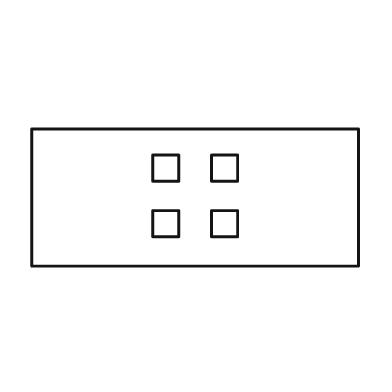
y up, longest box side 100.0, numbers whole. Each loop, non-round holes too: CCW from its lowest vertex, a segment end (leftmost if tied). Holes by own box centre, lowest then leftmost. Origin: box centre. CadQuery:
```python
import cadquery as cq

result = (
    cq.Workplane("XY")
    .moveTo(-50.0, -21.0)
    .lineTo(50.0, -21.0)
    .lineTo(50.0, 21.0)
    .lineTo(-50.0, 21.0)
    .close()
    .moveTo(-13.0, -12.0)
    .lineTo(-5.0, -12.0)
    .lineTo(-5.0, -4.0)
    .lineTo(-13.0, -4.0)
    .close()
    .moveTo(5.0, -12.0)
    .lineTo(13.0, -12.0)
    .lineTo(13.0, -4.0)
    .lineTo(5.0, -4.0)
    .close()
    .moveTo(-13.0, 5.0)
    .lineTo(-5.0, 5.0)
    .lineTo(-5.0, 13.0)
    .lineTo(-13.0, 13.0)
    .close()
    .moveTo(5.0, 5.0)
    .lineTo(13.0, 5.0)
    .lineTo(13.0, 13.0)
    .lineTo(5.0, 13.0)
    .close()
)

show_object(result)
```